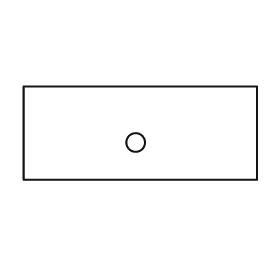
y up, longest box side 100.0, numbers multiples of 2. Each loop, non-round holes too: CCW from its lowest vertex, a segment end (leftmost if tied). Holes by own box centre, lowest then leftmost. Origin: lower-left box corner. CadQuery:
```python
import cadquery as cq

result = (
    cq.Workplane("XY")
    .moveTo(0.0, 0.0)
    .lineTo(100.0, 0.0)
    .lineTo(100.0, 40.0)
    .lineTo(0.0, 40.0)
    .close()
    .moveTo(48.0, 16.0)
    .circle(4.0)
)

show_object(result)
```